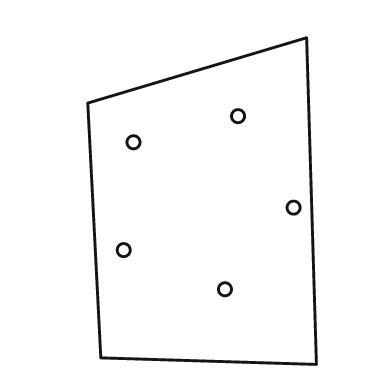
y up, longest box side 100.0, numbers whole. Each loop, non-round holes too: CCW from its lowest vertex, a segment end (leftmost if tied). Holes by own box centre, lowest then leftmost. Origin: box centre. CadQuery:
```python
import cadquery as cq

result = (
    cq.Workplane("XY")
    .moveTo(35.0, -50.0)
    .lineTo(32.0, 50.0)
    .lineTo(-35.0, 30.0)
    .lineTo(-31.0, -48.0)
    .close()
    .moveTo(7.0, -27.0)
    .circle(2.0)
    .moveTo(-24.0, -15.0)
    .circle(2.0)
    .moveTo(28.0, -2.0)
    .circle(2.0)
    .moveTo(-21.0, 18.0)
    .circle(2.0)
    .moveTo(11.0, 26.0)
    .circle(2.0)
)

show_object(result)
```